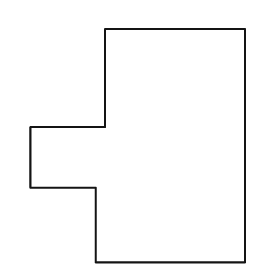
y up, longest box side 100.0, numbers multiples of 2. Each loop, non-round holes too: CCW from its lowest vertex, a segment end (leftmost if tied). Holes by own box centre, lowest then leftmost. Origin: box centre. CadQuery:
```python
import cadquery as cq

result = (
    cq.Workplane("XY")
    .moveTo(-18.0, -50.0)
    .lineTo(46.0, -50.0)
    .lineTo(46.0, 50.0)
    .lineTo(-14.0, 50.0)
    .lineTo(-14.0, 8.0)
    .lineTo(-46.0, 8.0)
    .lineTo(-46.0, -18.0)
    .lineTo(-18.0, -18.0)
    .close()
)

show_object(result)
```